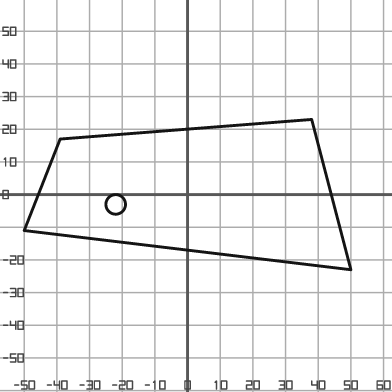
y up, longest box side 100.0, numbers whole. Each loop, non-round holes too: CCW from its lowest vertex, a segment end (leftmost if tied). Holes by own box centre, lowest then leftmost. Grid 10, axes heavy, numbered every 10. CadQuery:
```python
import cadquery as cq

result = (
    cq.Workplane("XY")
    .moveTo(50.0, -23.0)
    .lineTo(38.0, 23.0)
    .lineTo(-39.0, 17.0)
    .lineTo(-50.0, -11.0)
    .close()
    .moveTo(-22.0, -3.0)
    .circle(3.0)
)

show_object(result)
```